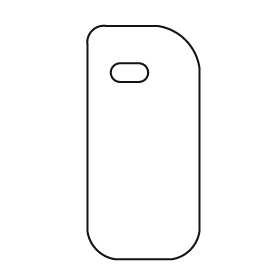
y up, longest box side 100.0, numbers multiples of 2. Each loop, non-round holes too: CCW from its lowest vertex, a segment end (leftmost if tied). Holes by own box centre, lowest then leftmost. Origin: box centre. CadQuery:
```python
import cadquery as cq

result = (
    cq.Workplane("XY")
    .moveTo(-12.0, -50.0)
    .lineTo(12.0, -50.0)
    .threePointArc((20.0, -46.0), (24.0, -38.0))
    .lineTo(24.0, 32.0)
    .threePointArc((18.0, 44.0), (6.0, 50.0))
    .lineTo(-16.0, 50.0)
    .threePointArc((-22.0, 48.0), (-24.0, 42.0))
    .lineTo(-24.0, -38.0)
    .threePointArc((-20.0, -46.0), (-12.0, -50.0))
    .close()
    .moveTo(-10.0, 26.0)
    .lineTo(-2.0, 26.0)
    .threePointArc((2.0, 30.0), (-2.0, 34.0))
    .lineTo(-10.0, 34.0)
    .threePointArc((-14.0, 30.0), (-10.0, 26.0))
    .close()
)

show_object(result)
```